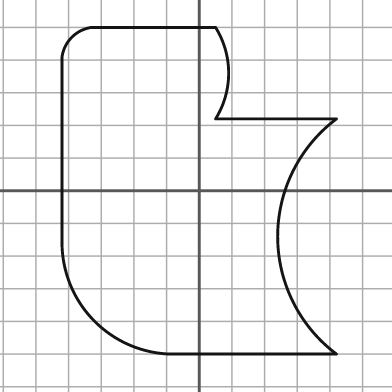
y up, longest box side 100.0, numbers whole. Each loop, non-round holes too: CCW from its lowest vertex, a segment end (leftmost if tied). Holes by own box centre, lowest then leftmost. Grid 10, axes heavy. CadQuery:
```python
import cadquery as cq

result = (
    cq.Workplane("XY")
    .moveTo(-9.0, -50.0)
    .lineTo(42.0, -50.0)
    .threePointArc((24.0, -14.0), (42.0, 22.0))
    .lineTo(5.0, 22.0)
    .threePointArc((9.0, 36.0), (5.0, 50.0))
    .lineTo(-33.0, 50.0)
    .threePointArc((-39.0, 47.0), (-42.0, 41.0))
    .lineTo(-42.0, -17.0)
    .threePointArc((-32.0, -40.0), (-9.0, -50.0))
    .close()
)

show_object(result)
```